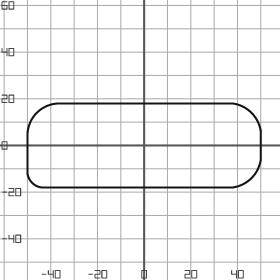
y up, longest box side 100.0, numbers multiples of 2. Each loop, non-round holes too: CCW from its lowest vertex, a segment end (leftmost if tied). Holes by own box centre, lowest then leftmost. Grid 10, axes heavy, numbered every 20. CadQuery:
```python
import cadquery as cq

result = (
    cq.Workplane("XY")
    .moveTo(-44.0, -18.0)
    .lineTo(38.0, -18.0)
    .threePointArc((46.0, -14.0), (50.0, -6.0))
    .lineTo(50.0, 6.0)
    .threePointArc((46.0, 14.0), (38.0, 18.0))
    .lineTo(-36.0, 18.0)
    .threePointArc((-46.0, 14.0), (-50.0, 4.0))
    .lineTo(-50.0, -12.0)
    .threePointArc((-48.0, -16.0), (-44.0, -18.0))
    .close()
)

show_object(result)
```